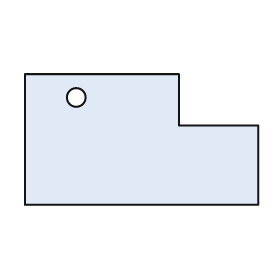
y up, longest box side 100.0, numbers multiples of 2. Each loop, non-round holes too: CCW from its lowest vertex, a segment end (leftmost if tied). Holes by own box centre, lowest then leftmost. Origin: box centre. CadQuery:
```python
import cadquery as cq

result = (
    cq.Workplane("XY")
    .moveTo(-50.0, -28.0)
    .lineTo(50.0, -28.0)
    .lineTo(50.0, 6.0)
    .lineTo(16.0, 6.0)
    .lineTo(16.0, 28.0)
    .lineTo(-50.0, 28.0)
    .close()
    .moveTo(-28.0, 18.0)
    .circle(4.0)
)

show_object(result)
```